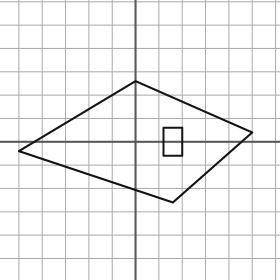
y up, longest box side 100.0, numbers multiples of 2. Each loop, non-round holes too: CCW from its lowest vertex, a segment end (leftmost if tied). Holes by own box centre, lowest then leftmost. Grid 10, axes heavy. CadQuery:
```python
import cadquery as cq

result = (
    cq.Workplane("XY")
    .moveTo(16.0, -26.0)
    .lineTo(50.0, 4.0)
    .lineTo(0.0, 26.0)
    .lineTo(-50.0, -4.0)
    .close()
    .moveTo(12.0, -6.0)
    .lineTo(20.0, -6.0)
    .lineTo(20.0, 6.0)
    .lineTo(12.0, 6.0)
    .close()
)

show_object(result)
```